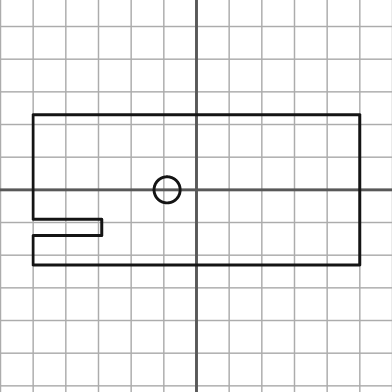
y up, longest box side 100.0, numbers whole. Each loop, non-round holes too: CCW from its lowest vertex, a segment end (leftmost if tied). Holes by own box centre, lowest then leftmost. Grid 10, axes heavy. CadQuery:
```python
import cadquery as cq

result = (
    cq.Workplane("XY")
    .moveTo(-50.0, -23.0)
    .lineTo(50.0, -23.0)
    .lineTo(50.0, 23.0)
    .lineTo(-50.0, 23.0)
    .lineTo(-50.0, -9.0)
    .lineTo(-29.0, -9.0)
    .lineTo(-29.0, -14.0)
    .lineTo(-50.0, -14.0)
    .close()
    .moveTo(-9.0, 0.0)
    .circle(4.0)
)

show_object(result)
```